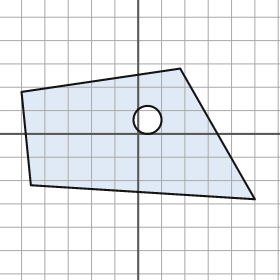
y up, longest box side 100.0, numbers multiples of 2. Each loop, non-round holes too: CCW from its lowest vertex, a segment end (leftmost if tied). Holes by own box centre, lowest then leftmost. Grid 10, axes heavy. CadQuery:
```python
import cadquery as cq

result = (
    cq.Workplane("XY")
    .moveTo(50.0, -28.0)
    .lineTo(18.0, 28.0)
    .lineTo(-50.0, 18.0)
    .lineTo(-46.0, -22.0)
    .close()
    .moveTo(4.0, 6.0)
    .circle(6.0)
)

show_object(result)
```